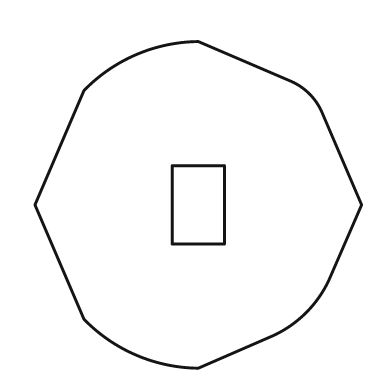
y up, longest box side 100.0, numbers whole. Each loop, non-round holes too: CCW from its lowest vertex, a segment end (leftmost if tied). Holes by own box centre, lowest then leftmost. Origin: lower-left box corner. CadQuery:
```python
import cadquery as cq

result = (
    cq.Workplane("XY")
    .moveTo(50.0, 0.0)
    .lineTo(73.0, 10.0)
    .threePointArc((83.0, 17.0), (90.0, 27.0))
    .lineTo(100.0, 50.0)
    .lineTo(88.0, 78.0)
    .threePointArc((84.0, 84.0), (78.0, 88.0))
    .lineTo(50.0, 100.0)
    .threePointArc((31.0, 96.0), (15.0, 85.0))
    .lineTo(0.0, 50.0)
    .lineTo(15.0, 15.0)
    .threePointArc((31.0, 4.0), (50.0, 0.0))
    .close()
    .moveTo(42.0, 38.0)
    .lineTo(58.0, 38.0)
    .lineTo(58.0, 62.0)
    .lineTo(42.0, 62.0)
    .close()
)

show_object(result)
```